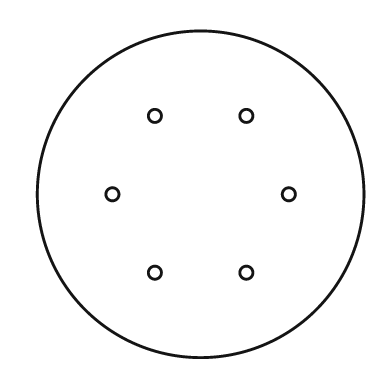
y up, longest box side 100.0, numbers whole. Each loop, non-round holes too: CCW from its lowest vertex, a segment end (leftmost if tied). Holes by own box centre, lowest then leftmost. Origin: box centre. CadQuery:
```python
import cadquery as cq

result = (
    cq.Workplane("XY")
    .moveTo(0.0, 0.0)
    .circle(50.0)
    .moveTo(-14.0, -24.0)
    .circle(2.0)
    .moveTo(14.0, -24.0)
    .circle(2.0)
    .moveTo(-27.0, 0.0)
    .circle(2.0)
    .moveTo(27.0, 0.0)
    .circle(2.0)
    .moveTo(-14.0, 24.0)
    .circle(2.0)
    .moveTo(14.0, 24.0)
    .circle(2.0)
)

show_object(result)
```